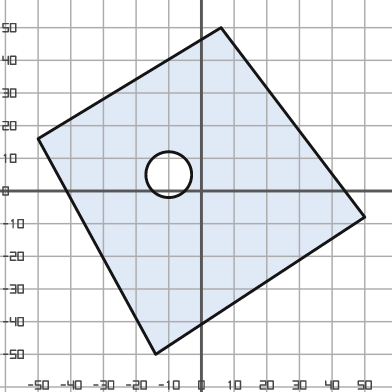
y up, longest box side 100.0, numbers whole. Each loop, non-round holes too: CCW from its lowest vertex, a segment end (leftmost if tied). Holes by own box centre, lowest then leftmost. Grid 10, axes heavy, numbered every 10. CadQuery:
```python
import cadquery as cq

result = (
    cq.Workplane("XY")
    .moveTo(-14.0, -50.0)
    .lineTo(50.0, -8.0)
    .lineTo(6.0, 50.0)
    .lineTo(-50.0, 16.0)
    .close()
    .moveTo(-10.0, 5.0)
    .circle(7.0)
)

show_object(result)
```